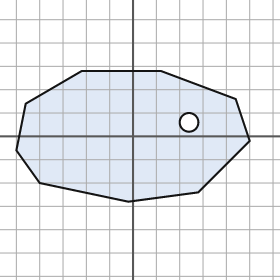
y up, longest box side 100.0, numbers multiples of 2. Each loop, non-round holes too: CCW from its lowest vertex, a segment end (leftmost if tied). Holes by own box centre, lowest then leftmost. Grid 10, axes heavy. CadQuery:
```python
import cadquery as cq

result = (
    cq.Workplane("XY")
    .moveTo(-2.0, -28.0)
    .lineTo(28.0, -24.0)
    .lineTo(50.0, -2.0)
    .lineTo(44.0, 16.0)
    .lineTo(12.0, 28.0)
    .lineTo(-22.0, 28.0)
    .lineTo(-46.0, 14.0)
    .lineTo(-50.0, -6.0)
    .lineTo(-40.0, -20.0)
    .close()
    .moveTo(24.0, 6.0)
    .circle(4.0)
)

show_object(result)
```